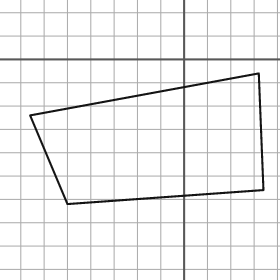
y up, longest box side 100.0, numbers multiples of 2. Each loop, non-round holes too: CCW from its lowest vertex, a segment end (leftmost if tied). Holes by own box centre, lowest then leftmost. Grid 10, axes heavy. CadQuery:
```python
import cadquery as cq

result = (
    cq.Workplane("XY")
    .moveTo(-50.0, -62.0)
    .lineTo(34.0, -56.0)
    .lineTo(32.0, -6.0)
    .lineTo(-66.0, -24.0)
    .close()
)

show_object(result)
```